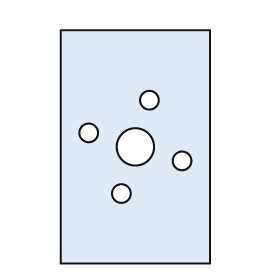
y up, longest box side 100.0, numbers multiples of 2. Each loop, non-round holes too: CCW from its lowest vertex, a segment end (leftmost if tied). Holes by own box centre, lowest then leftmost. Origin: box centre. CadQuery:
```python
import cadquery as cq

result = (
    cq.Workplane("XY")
    .moveTo(-32.0, -50.0)
    .lineTo(32.0, -50.0)
    .lineTo(32.0, 50.0)
    .lineTo(-32.0, 50.0)
    .close()
    .moveTo(-6.0, -20.0)
    .circle(4.0)
    .moveTo(20.0, -6.0)
    .circle(4.0)
    .moveTo(0.0, 0.0)
    .circle(8.0)
    .moveTo(-20.0, 6.0)
    .circle(4.0)
    .moveTo(6.0, 20.0)
    .circle(4.0)
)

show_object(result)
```